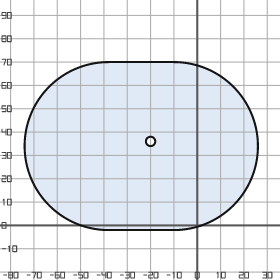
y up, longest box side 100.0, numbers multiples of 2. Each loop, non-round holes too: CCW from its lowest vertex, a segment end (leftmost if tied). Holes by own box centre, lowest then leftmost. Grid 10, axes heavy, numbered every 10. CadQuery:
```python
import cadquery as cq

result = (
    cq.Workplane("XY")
    .moveTo(-38.0, -2.0)
    .lineTo(-10.0, -2.0)
    .threePointArc((26.0, 34.0), (-10.0, 70.0))
    .lineTo(-38.0, 70.0)
    .threePointArc((-74.0, 34.0), (-38.0, -2.0))
    .close()
    .moveTo(-20.0, 36.0)
    .circle(2.0)
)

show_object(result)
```